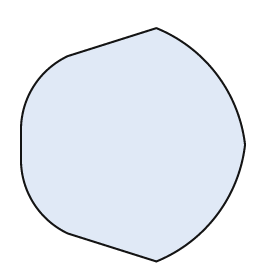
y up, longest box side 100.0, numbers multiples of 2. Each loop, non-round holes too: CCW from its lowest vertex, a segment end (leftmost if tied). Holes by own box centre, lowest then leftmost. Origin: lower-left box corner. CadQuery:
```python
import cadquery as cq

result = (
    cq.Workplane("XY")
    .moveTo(58.0, 0.0)
    .threePointArc((84.0, 20.0), (96.0, 50.0))
    .threePointArc((84.0, 80.0), (58.0, 100.0))
    .lineTo(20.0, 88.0)
    .threePointArc((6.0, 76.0), (0.0, 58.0))
    .lineTo(0.0, 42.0)
    .threePointArc((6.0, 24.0), (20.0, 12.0))
    .close()
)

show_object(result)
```